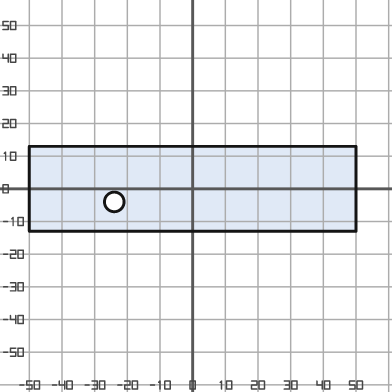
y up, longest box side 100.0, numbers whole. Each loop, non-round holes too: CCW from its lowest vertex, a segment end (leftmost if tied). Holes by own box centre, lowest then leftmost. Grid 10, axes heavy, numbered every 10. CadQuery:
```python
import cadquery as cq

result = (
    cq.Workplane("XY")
    .moveTo(-50.0, -13.0)
    .lineTo(50.0, -13.0)
    .lineTo(50.0, 13.0)
    .lineTo(-50.0, 13.0)
    .close()
    .moveTo(-24.0, -4.0)
    .circle(3.0)
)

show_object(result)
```